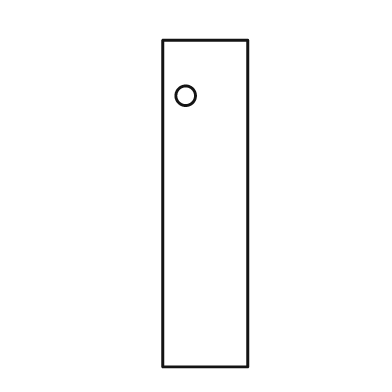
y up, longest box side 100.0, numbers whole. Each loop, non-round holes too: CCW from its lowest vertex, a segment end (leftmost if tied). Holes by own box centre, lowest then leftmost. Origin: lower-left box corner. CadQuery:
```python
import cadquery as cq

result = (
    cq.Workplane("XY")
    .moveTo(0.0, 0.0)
    .lineTo(26.0, 0.0)
    .lineTo(26.0, 100.0)
    .lineTo(0.0, 100.0)
    .close()
    .moveTo(7.0, 83.0)
    .circle(3.0)
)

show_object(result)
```